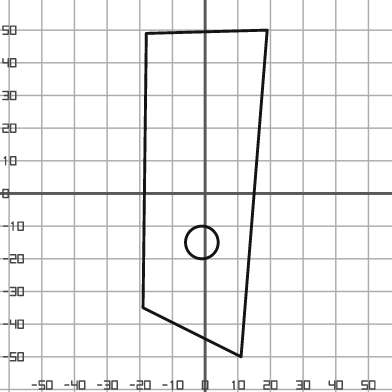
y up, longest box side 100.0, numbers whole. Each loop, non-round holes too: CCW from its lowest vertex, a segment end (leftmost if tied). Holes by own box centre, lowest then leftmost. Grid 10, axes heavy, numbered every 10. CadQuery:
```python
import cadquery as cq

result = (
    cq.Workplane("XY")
    .moveTo(11.0, -50.0)
    .lineTo(19.0, 50.0)
    .lineTo(-18.0, 49.0)
    .lineTo(-19.0, -35.0)
    .close()
    .moveTo(-1.0, -15.0)
    .circle(5.0)
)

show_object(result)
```